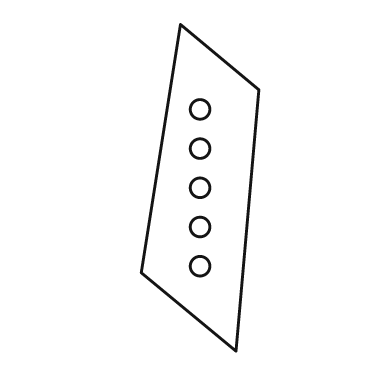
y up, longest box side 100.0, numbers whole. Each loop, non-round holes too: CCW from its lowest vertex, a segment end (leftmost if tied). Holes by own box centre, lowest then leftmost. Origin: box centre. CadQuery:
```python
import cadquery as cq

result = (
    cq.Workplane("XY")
    .moveTo(11.0, -50.0)
    .lineTo(18.0, 30.0)
    .lineTo(-6.0, 50.0)
    .lineTo(-18.0, -26.0)
    .close()
    .moveTo(0.0, -24.0)
    .circle(3.0)
    .moveTo(0.0, -12.0)
    .circle(3.0)
    .moveTo(0.0, 0.0)
    .circle(3.0)
    .moveTo(0.0, 12.0)
    .circle(3.0)
    .moveTo(0.0, 24.0)
    .circle(3.0)
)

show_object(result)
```